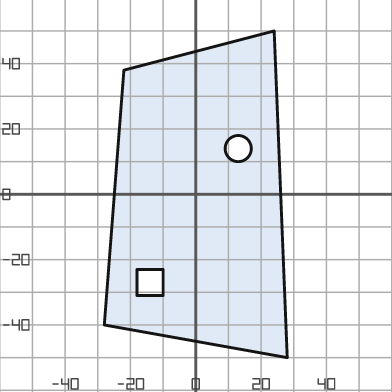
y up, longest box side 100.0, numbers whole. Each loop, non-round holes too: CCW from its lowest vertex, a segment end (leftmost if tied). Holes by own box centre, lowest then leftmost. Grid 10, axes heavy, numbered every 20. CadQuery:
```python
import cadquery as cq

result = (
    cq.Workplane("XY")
    .moveTo(28.0, -50.0)
    .lineTo(24.0, 50.0)
    .lineTo(-22.0, 38.0)
    .lineTo(-28.0, -40.0)
    .close()
    .moveTo(-18.0, -31.0)
    .lineTo(-10.0, -31.0)
    .lineTo(-10.0, -23.0)
    .lineTo(-18.0, -23.0)
    .close()
    .moveTo(13.0, 14.0)
    .circle(4.0)
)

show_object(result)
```